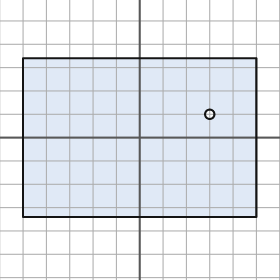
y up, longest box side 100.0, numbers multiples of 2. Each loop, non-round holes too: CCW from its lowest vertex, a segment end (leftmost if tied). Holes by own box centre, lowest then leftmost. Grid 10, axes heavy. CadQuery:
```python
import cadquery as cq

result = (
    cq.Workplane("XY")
    .moveTo(-50.0, -34.0)
    .lineTo(50.0, -34.0)
    .lineTo(50.0, 34.0)
    .lineTo(-50.0, 34.0)
    .close()
    .moveTo(30.0, 10.0)
    .circle(2.0)
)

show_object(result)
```